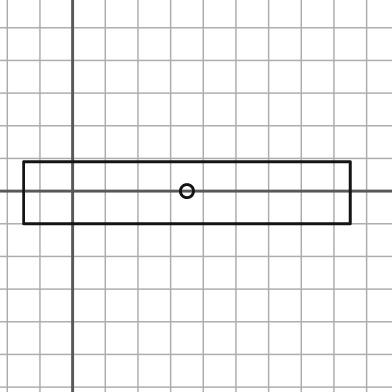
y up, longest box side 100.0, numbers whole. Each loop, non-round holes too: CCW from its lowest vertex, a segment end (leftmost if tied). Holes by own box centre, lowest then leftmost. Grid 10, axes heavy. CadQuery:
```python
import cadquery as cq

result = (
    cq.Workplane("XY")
    .moveTo(-15.0, -10.0)
    .lineTo(85.0, -10.0)
    .lineTo(85.0, 9.0)
    .lineTo(-15.0, 9.0)
    .close()
    .moveTo(35.0, 0.0)
    .circle(2.0)
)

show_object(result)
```